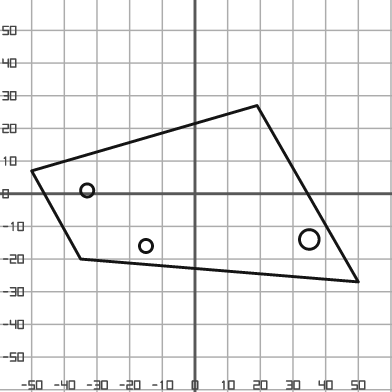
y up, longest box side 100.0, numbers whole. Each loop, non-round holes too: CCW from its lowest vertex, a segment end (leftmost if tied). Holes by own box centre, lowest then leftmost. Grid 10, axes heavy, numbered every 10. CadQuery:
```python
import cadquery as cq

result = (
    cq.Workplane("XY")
    .moveTo(50.0, -27.0)
    .lineTo(19.0, 27.0)
    .lineTo(-50.0, 7.0)
    .lineTo(-35.0, -20.0)
    .close()
    .moveTo(-15.0, -16.0)
    .circle(2.0)
    .moveTo(35.0, -14.0)
    .circle(3.0)
    .moveTo(-33.0, 1.0)
    .circle(2.0)
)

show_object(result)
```